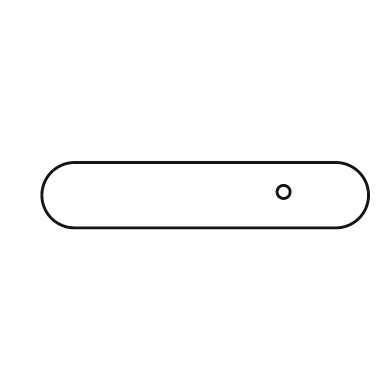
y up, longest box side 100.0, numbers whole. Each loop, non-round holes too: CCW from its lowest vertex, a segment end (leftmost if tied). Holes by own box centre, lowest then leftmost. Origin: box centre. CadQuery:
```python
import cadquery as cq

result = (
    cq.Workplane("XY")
    .moveTo(-40.0, -10.0)
    .lineTo(40.0, -10.0)
    .threePointArc((50.0, 0.0), (40.0, 10.0))
    .lineTo(-40.0, 10.0)
    .threePointArc((-50.0, 0.0), (-40.0, -10.0))
    .close()
    .moveTo(24.0, 1.0)
    .circle(2.0)
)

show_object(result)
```